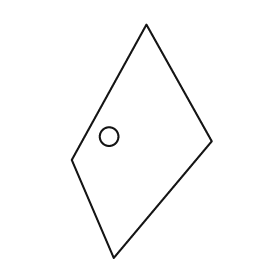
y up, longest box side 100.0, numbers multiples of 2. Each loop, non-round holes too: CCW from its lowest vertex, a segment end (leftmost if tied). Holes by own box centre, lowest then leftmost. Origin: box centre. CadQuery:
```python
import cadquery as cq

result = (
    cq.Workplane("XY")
    .moveTo(-12.0, -50.0)
    .lineTo(30.0, 0.0)
    .lineTo(2.0, 50.0)
    .lineTo(-30.0, -8.0)
    .close()
    .moveTo(-14.0, 2.0)
    .circle(4.0)
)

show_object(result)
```